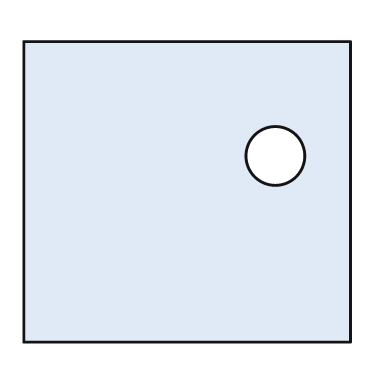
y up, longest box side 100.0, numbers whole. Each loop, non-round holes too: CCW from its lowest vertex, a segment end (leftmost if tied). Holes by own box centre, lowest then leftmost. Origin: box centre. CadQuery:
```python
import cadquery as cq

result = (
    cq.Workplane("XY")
    .moveTo(-50.0, -46.0)
    .lineTo(50.0, -46.0)
    .lineTo(50.0, 46.0)
    .lineTo(-50.0, 46.0)
    .close()
    .moveTo(27.0, 11.0)
    .circle(9.0)
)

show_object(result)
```